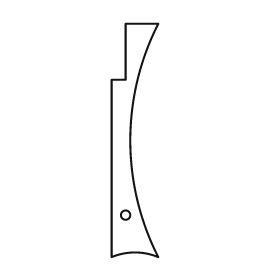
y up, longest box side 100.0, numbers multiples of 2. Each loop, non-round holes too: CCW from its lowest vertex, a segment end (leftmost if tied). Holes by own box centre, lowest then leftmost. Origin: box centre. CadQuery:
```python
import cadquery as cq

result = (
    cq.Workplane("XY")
    .moveTo(-10.0, -50.0)
    .threePointArc((0.0, -48.0), (10.0, -50.0))
    .threePointArc((-2.0, 0.0), (10.0, 50.0))
    .lineTo(-4.0, 50.0)
    .lineTo(-4.0, 26.0)
    .lineTo(-10.0, 26.0)
    .close()
    .moveTo(-4.0, -32.0)
    .circle(2.0)
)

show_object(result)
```